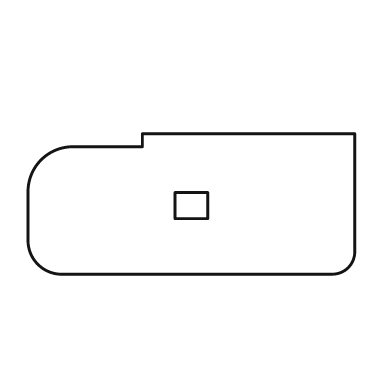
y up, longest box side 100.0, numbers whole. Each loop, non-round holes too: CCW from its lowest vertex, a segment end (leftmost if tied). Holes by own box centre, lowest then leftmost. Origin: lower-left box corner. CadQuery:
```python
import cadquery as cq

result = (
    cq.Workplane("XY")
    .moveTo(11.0, 0.0)
    .lineTo(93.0, 0.0)
    .threePointArc((98.0, 2.0), (100.0, 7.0))
    .lineTo(100.0, 43.0)
    .lineTo(35.0, 43.0)
    .lineTo(35.0, 39.0)
    .lineTo(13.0, 39.0)
    .threePointArc((4.0, 35.0), (0.0, 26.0))
    .lineTo(0.0, 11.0)
    .threePointArc((3.0, 3.0), (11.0, 0.0))
    .close()
    .moveTo(45.0, 17.0)
    .lineTo(55.0, 17.0)
    .lineTo(55.0, 25.0)
    .lineTo(45.0, 25.0)
    .close()
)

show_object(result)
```